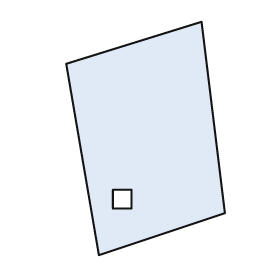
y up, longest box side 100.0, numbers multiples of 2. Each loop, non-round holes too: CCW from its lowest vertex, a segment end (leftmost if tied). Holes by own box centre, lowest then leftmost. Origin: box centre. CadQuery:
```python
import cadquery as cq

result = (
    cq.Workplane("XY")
    .moveTo(-20.0, -50.0)
    .lineTo(34.0, -32.0)
    .lineTo(24.0, 50.0)
    .lineTo(-34.0, 32.0)
    .close()
    .moveTo(-14.0, -30.0)
    .lineTo(-6.0, -30.0)
    .lineTo(-6.0, -22.0)
    .lineTo(-14.0, -22.0)
    .close()
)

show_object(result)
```